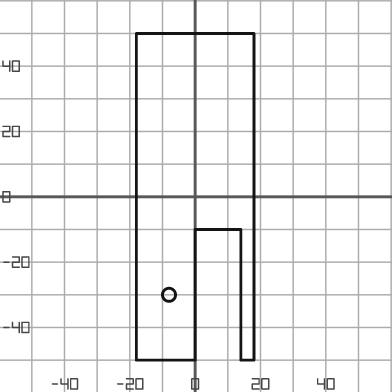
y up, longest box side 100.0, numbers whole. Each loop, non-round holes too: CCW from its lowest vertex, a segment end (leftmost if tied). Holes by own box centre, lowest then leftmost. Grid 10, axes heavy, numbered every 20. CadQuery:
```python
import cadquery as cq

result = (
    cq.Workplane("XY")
    .moveTo(-18.0, -50.0)
    .lineTo(0.0, -50.0)
    .lineTo(0.0, -10.0)
    .lineTo(14.0, -10.0)
    .lineTo(14.0, -50.0)
    .lineTo(18.0, -50.0)
    .lineTo(18.0, 50.0)
    .lineTo(-18.0, 50.0)
    .close()
    .moveTo(-8.0, -30.0)
    .circle(2.0)
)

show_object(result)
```